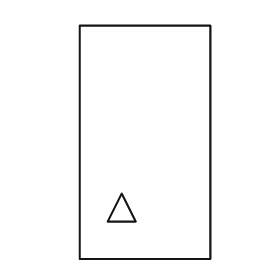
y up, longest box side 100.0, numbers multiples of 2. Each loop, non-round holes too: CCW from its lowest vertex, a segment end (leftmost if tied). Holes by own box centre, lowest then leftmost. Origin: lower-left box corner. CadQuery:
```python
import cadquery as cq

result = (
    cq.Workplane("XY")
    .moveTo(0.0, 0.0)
    .lineTo(56.0, 0.0)
    .lineTo(56.0, 100.0)
    .lineTo(0.0, 100.0)
    .close()
    .moveTo(12.0, 16.0)
    .lineTo(24.0, 16.0)
    .lineTo(18.0, 28.0)
    .close()
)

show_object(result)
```